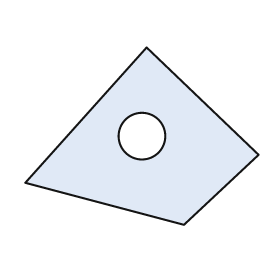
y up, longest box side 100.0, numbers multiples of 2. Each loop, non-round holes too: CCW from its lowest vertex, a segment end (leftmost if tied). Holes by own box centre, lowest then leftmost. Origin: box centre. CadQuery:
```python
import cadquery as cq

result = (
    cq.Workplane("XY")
    .moveTo(18.0, -38.0)
    .lineTo(50.0, -8.0)
    .lineTo(2.0, 38.0)
    .lineTo(-50.0, -20.0)
    .close()
    .moveTo(0.0, 0.0)
    .circle(10.0)
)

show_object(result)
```